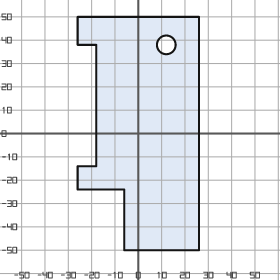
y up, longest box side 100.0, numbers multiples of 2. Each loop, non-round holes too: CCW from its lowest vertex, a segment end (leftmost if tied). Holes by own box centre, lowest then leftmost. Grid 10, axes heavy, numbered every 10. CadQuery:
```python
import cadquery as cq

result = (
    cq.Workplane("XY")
    .moveTo(-6.0, -50.0)
    .lineTo(26.0, -50.0)
    .lineTo(26.0, 50.0)
    .lineTo(-26.0, 50.0)
    .lineTo(-26.0, 38.0)
    .lineTo(-18.0, 38.0)
    .lineTo(-18.0, -14.0)
    .lineTo(-26.0, -14.0)
    .lineTo(-26.0, -24.0)
    .lineTo(-6.0, -24.0)
    .close()
    .moveTo(12.0, 38.0)
    .circle(4.0)
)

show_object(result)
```